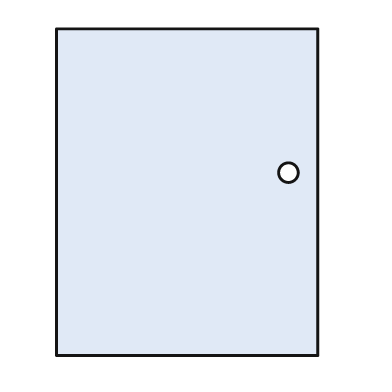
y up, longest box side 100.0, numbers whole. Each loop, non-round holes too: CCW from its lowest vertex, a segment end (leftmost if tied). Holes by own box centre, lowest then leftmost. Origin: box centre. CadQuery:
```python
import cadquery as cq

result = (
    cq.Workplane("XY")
    .moveTo(-40.0, -50.0)
    .lineTo(40.0, -50.0)
    .lineTo(40.0, 50.0)
    .lineTo(-40.0, 50.0)
    .close()
    .moveTo(31.0, 6.0)
    .circle(3.0)
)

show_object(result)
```